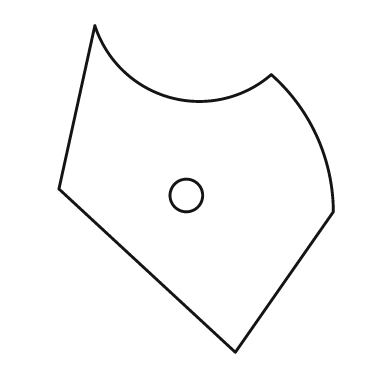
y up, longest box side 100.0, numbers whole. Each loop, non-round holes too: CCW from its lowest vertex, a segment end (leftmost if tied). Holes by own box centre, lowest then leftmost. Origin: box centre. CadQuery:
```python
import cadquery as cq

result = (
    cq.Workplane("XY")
    .moveTo(12.0, -50.0)
    .lineTo(42.0, -7.0)
    .threePointArc((37.0, 16.0), (23.0, 35.0))
    .threePointArc((-8.0, 28.0), (-31.0, 50.0))
    .lineTo(-42.0, 0.0)
    .close()
    .moveTo(-3.0, -2.0)
    .circle(5.0)
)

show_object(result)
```